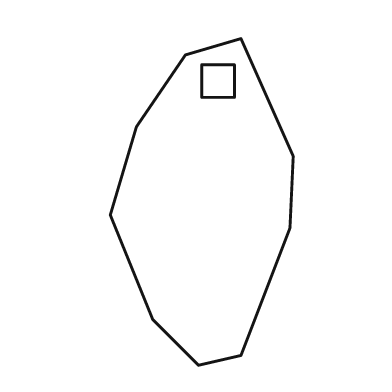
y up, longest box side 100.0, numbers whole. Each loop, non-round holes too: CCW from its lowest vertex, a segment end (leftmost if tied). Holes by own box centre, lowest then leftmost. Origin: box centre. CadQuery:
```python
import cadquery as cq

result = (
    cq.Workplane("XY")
    .moveTo(-1.0, -50.0)
    .lineTo(12.0, -47.0)
    .lineTo(27.0, -8.0)
    .lineTo(28.0, 14.0)
    .lineTo(12.0, 50.0)
    .lineTo(-5.0, 45.0)
    .lineTo(-20.0, 23.0)
    .lineTo(-28.0, -4.0)
    .lineTo(-15.0, -36.0)
    .close()
    .moveTo(0.0, 32.0)
    .lineTo(10.0, 32.0)
    .lineTo(10.0, 42.0)
    .lineTo(0.0, 42.0)
    .close()
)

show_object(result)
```